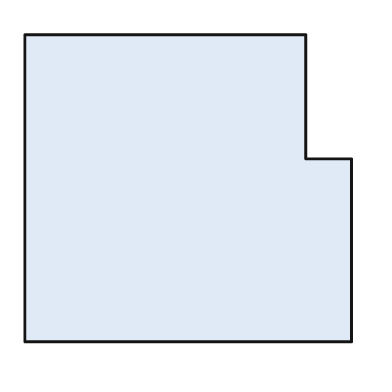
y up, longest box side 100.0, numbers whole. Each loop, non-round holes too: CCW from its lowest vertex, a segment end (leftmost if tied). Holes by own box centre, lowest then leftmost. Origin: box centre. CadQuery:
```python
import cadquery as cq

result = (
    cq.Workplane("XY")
    .moveTo(-50.0, -47.0)
    .lineTo(50.0, -47.0)
    .lineTo(50.0, 9.0)
    .lineTo(36.0, 9.0)
    .lineTo(36.0, 47.0)
    .lineTo(-50.0, 47.0)
    .close()
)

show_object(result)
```